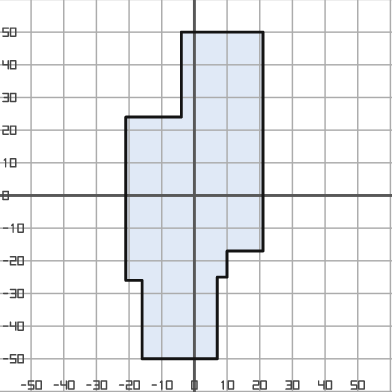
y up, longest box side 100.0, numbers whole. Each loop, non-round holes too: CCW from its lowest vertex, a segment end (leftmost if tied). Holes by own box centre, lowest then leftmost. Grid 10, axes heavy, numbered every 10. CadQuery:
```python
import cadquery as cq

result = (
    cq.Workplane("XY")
    .moveTo(-16.0, -50.0)
    .lineTo(7.0, -50.0)
    .lineTo(7.0, -25.0)
    .lineTo(10.0, -25.0)
    .lineTo(10.0, -17.0)
    .lineTo(21.0, -17.0)
    .lineTo(21.0, 50.0)
    .lineTo(-4.0, 50.0)
    .lineTo(-4.0, 24.0)
    .lineTo(-21.0, 24.0)
    .lineTo(-21.0, -26.0)
    .lineTo(-16.0, -26.0)
    .close()
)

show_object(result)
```